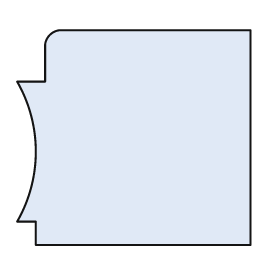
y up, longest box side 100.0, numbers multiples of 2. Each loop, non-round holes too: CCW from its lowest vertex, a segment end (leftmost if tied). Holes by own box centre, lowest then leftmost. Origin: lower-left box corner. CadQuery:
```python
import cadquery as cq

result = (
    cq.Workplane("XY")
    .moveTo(8.0, 0.0)
    .lineTo(100.0, 0.0)
    .lineTo(100.0, 92.0)
    .lineTo(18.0, 92.0)
    .threePointArc((14.0, 90.0), (12.0, 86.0))
    .lineTo(12.0, 70.0)
    .lineTo(0.0, 70.0)
    .threePointArc((8.0, 40.0), (0.0, 10.0))
    .lineTo(8.0, 10.0)
    .close()
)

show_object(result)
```